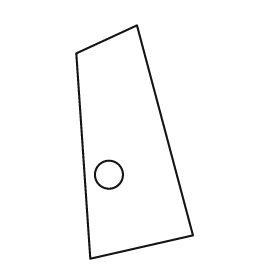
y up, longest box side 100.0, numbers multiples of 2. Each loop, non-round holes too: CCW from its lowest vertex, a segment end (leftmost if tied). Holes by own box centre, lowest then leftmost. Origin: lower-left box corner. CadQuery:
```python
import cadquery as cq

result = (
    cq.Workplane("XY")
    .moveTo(6.0, 0.0)
    .lineTo(50.0, 10.0)
    .lineTo(26.0, 100.0)
    .lineTo(0.0, 88.0)
    .close()
    .moveTo(14.0, 36.0)
    .circle(6.0)
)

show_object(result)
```